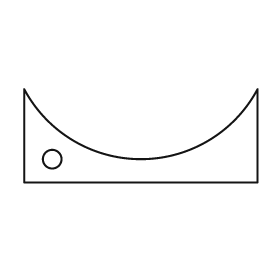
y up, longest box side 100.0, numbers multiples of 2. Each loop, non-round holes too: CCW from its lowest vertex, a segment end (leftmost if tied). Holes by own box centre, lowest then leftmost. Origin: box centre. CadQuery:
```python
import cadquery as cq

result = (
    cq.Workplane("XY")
    .moveTo(-50.0, -20.0)
    .lineTo(50.0, -20.0)
    .lineTo(50.0, 20.0)
    .threePointArc((0.0, -10.0), (-50.0, 20.0))
    .close()
    .moveTo(-38.0, -10.0)
    .circle(4.0)
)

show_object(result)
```